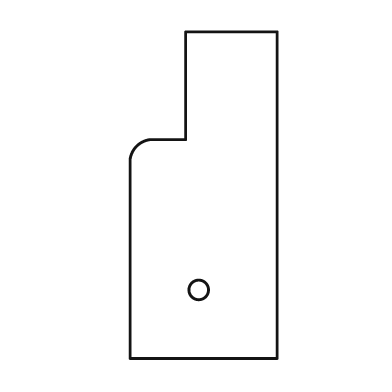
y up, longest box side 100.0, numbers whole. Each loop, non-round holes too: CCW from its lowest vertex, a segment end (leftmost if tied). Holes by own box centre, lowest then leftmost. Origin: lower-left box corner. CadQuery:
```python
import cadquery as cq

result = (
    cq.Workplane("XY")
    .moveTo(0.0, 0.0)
    .lineTo(45.0, 0.0)
    .lineTo(45.0, 100.0)
    .lineTo(17.0, 100.0)
    .lineTo(17.0, 67.0)
    .lineTo(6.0, 67.0)
    .threePointArc((2.0, 65.0), (0.0, 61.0))
    .close()
    .moveTo(21.0, 21.0)
    .circle(3.0)
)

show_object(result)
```